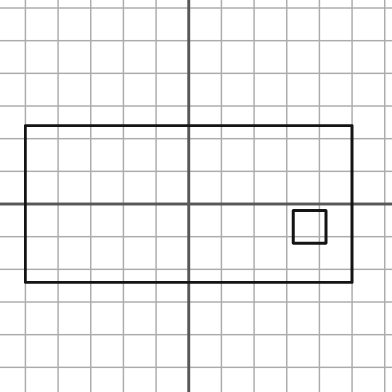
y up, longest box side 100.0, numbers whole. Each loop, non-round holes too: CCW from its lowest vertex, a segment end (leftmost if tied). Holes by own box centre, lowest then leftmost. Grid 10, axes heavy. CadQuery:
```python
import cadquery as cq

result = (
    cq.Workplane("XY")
    .moveTo(-50.0, -24.0)
    .lineTo(50.0, -24.0)
    .lineTo(50.0, 24.0)
    .lineTo(-50.0, 24.0)
    .close()
    .moveTo(32.0, -12.0)
    .lineTo(42.0, -12.0)
    .lineTo(42.0, -2.0)
    .lineTo(32.0, -2.0)
    .close()
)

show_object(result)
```